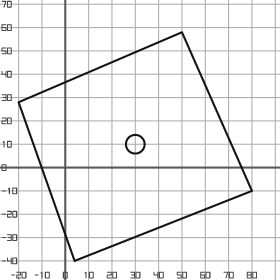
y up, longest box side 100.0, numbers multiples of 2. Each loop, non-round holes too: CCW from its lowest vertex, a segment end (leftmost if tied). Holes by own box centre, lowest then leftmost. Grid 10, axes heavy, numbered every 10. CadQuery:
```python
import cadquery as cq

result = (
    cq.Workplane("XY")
    .moveTo(4.0, -40.0)
    .lineTo(80.0, -10.0)
    .lineTo(50.0, 58.0)
    .lineTo(-20.0, 28.0)
    .close()
    .moveTo(30.0, 10.0)
    .circle(4.0)
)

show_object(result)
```